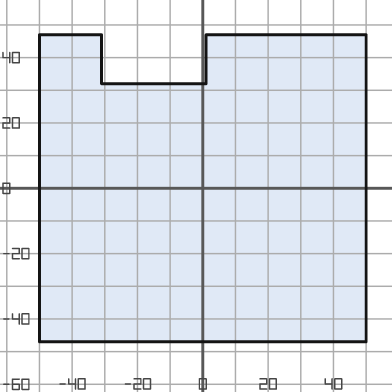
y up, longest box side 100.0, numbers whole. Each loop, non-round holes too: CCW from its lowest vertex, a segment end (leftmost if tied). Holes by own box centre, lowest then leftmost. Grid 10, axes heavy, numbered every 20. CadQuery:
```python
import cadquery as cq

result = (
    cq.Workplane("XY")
    .moveTo(-50.0, -47.0)
    .lineTo(50.0, -47.0)
    .lineTo(50.0, 47.0)
    .lineTo(1.0, 47.0)
    .lineTo(1.0, 32.0)
    .lineTo(-31.0, 32.0)
    .lineTo(-31.0, 47.0)
    .lineTo(-50.0, 47.0)
    .close()
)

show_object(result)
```